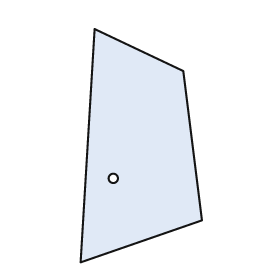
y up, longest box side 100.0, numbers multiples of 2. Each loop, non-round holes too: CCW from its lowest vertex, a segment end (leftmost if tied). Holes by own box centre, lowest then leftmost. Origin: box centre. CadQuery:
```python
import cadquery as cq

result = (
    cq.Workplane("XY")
    .moveTo(-26.0, -50.0)
    .lineTo(26.0, -32.0)
    .lineTo(18.0, 32.0)
    .lineTo(-20.0, 50.0)
    .close()
    .moveTo(-12.0, -14.0)
    .circle(2.0)
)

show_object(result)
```